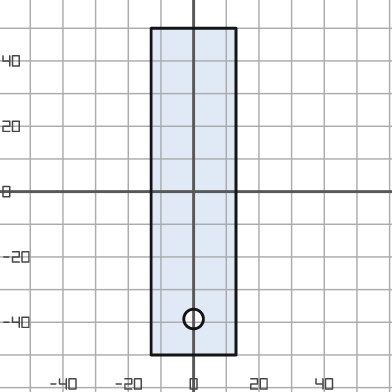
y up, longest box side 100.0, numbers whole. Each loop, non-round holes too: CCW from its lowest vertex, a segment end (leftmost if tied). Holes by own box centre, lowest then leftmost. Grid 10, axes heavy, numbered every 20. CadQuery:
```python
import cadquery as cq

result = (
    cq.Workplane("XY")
    .moveTo(-13.0, -50.0)
    .lineTo(13.0, -50.0)
    .lineTo(13.0, 50.0)
    .lineTo(-13.0, 50.0)
    .close()
    .moveTo(0.0, -39.0)
    .circle(3.0)
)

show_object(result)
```